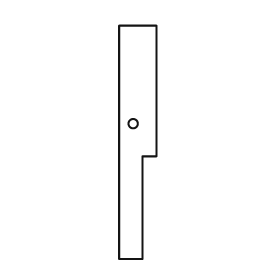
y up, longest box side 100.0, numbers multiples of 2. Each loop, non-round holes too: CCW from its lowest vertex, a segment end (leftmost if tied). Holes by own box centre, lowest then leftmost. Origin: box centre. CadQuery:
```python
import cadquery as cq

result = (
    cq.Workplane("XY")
    .moveTo(-8.0, -50.0)
    .lineTo(2.0, -50.0)
    .lineTo(2.0, -6.0)
    .lineTo(8.0, -6.0)
    .lineTo(8.0, 50.0)
    .lineTo(-8.0, 50.0)
    .close()
    .moveTo(-2.0, 8.0)
    .circle(2.0)
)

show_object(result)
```